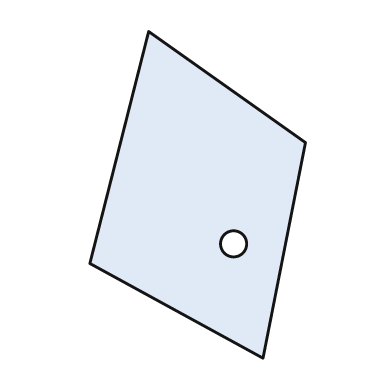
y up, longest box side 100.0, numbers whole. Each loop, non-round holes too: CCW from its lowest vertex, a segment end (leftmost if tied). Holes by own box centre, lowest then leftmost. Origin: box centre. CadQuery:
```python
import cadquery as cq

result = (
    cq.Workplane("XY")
    .moveTo(20.0, -50.0)
    .lineTo(33.0, 16.0)
    .lineTo(-15.0, 50.0)
    .lineTo(-33.0, -21.0)
    .close()
    .moveTo(11.0, -15.0)
    .circle(4.0)
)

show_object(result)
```